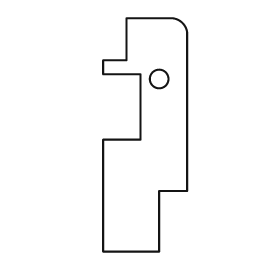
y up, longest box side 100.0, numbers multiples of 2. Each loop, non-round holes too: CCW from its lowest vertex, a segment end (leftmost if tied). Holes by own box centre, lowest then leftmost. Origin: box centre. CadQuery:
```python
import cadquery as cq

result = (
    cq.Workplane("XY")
    .moveTo(-18.0, -50.0)
    .lineTo(6.0, -50.0)
    .lineTo(6.0, -24.0)
    .lineTo(18.0, -24.0)
    .lineTo(18.0, 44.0)
    .threePointArc((16.0, 48.0), (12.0, 50.0))
    .lineTo(-8.0, 50.0)
    .lineTo(-8.0, 32.0)
    .lineTo(-18.0, 32.0)
    .lineTo(-18.0, 26.0)
    .lineTo(-2.0, 26.0)
    .lineTo(-2.0, -2.0)
    .lineTo(-18.0, -2.0)
    .close()
    .moveTo(6.0, 24.0)
    .circle(4.0)
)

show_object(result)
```